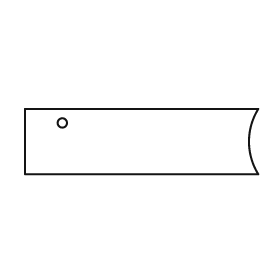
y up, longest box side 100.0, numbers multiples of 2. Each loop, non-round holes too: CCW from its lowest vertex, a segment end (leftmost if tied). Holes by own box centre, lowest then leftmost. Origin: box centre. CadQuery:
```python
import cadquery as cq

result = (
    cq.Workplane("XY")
    .moveTo(-50.0, -14.0)
    .lineTo(50.0, -14.0)
    .threePointArc((46.0, 0.0), (50.0, 14.0))
    .lineTo(-50.0, 14.0)
    .close()
    .moveTo(-34.0, 8.0)
    .circle(2.0)
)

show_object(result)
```